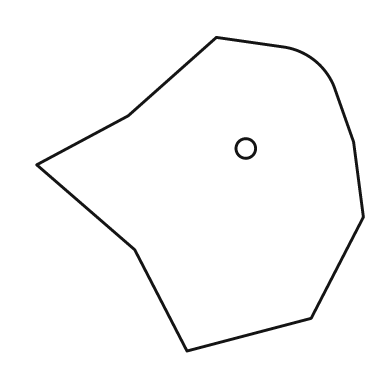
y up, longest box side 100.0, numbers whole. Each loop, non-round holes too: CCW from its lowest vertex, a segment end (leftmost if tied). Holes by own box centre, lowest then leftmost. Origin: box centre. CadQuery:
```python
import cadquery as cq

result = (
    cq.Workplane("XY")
    .moveTo(-4.0, -48.0)
    .lineTo(34.0, -38.0)
    .lineTo(50.0, -7.0)
    .lineTo(47.0, 16.0)
    .lineTo(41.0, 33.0)
    .threePointArc((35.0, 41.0), (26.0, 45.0))
    .lineTo(5.0, 48.0)
    .lineTo(-22.0, 24.0)
    .lineTo(-50.0, 9.0)
    .lineTo(-20.0, -17.0)
    .close()
    .moveTo(14.0, 14.0)
    .circle(3.0)
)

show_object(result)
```